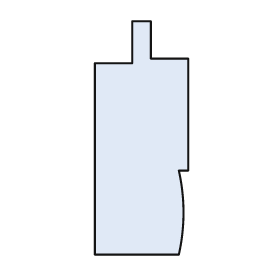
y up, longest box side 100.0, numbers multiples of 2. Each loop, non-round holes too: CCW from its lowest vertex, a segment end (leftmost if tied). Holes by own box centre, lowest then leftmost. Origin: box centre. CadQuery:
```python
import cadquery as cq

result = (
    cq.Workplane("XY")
    .moveTo(-20.0, -50.0)
    .lineTo(16.0, -50.0)
    .threePointArc((18.0, -32.0), (16.0, -14.0))
    .lineTo(20.0, -14.0)
    .lineTo(20.0, 34.0)
    .lineTo(4.0, 34.0)
    .lineTo(4.0, 50.0)
    .lineTo(-4.0, 50.0)
    .lineTo(-4.0, 32.0)
    .lineTo(-20.0, 32.0)
    .close()
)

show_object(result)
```